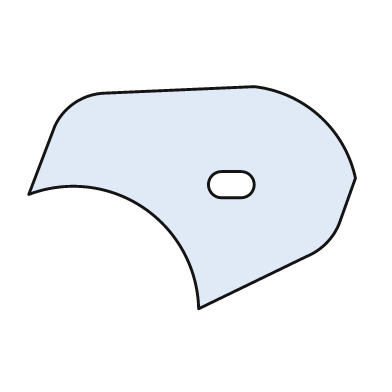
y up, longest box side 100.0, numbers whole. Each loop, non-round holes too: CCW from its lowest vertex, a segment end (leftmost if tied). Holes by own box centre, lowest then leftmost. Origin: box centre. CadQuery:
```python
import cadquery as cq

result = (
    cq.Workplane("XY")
    .moveTo(2.0, -34.0)
    .lineTo(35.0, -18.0)
    .threePointArc((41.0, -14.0), (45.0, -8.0))
    .lineTo(50.0, 6.0)
    .threePointArc((39.0, 25.0), (19.0, 34.0))
    .lineTo(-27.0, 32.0)
    .threePointArc((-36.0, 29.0), (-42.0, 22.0))
    .lineTo(-50.0, 1.0)
    .threePointArc((-15.0, -3.0), (2.0, -34.0))
    .close()
    .moveTo(9.0, 0.0)
    .lineTo(15.0, 0.0)
    .threePointArc((19.0, 4.0), (15.0, 8.0))
    .lineTo(9.0, 8.0)
    .threePointArc((5.0, 4.0), (9.0, 0.0))
    .close()
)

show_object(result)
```